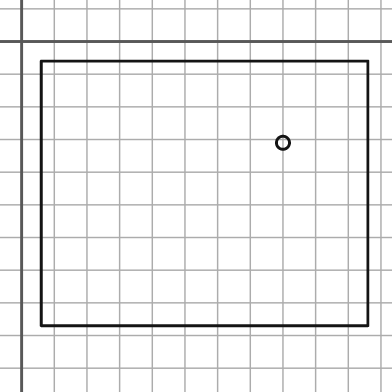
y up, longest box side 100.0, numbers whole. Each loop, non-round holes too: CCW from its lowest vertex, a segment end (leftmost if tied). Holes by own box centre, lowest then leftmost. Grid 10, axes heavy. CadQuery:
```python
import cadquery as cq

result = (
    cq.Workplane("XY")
    .moveTo(6.0, -87.0)
    .lineTo(106.0, -87.0)
    .lineTo(106.0, -6.0)
    .lineTo(6.0, -6.0)
    .close()
    .moveTo(80.0, -31.0)
    .circle(2.0)
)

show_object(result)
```